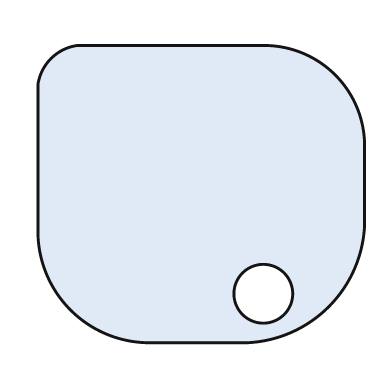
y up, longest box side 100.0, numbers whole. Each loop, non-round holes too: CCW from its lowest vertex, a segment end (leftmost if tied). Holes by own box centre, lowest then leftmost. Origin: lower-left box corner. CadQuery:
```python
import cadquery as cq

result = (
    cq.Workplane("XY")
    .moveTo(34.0, 0.0)
    .lineTo(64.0, 0.0)
    .threePointArc((89.0, 11.0), (100.0, 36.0))
    .lineTo(100.0, 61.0)
    .threePointArc((91.0, 82.0), (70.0, 91.0))
    .lineTo(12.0, 91.0)
    .threePointArc((4.0, 87.0), (0.0, 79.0))
    .lineTo(0.0, 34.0)
    .threePointArc((10.0, 10.0), (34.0, 0.0))
    .close()
    .moveTo(69.0, 15.0)
    .circle(9.0)
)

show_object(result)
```